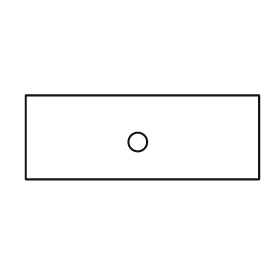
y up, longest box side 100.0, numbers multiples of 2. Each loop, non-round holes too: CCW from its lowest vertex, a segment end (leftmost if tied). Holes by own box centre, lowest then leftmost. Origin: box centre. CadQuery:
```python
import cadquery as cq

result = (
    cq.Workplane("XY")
    .moveTo(-50.0, -18.0)
    .lineTo(50.0, -18.0)
    .lineTo(50.0, 18.0)
    .lineTo(-50.0, 18.0)
    .close()
    .moveTo(-2.0, -2.0)
    .circle(4.0)
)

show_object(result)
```